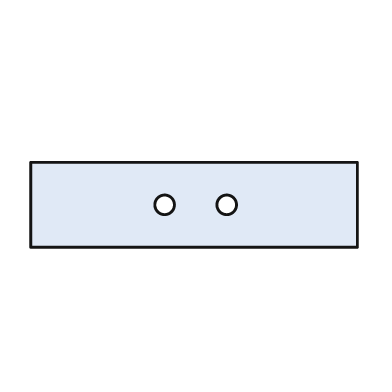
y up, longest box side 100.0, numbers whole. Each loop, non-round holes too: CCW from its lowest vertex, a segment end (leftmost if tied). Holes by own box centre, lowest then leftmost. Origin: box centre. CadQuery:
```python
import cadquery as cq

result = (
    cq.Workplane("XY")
    .moveTo(-50.0, -13.0)
    .lineTo(50.0, -13.0)
    .lineTo(50.0, 13.0)
    .lineTo(-50.0, 13.0)
    .close()
    .moveTo(-9.0, 0.0)
    .circle(3.0)
    .moveTo(10.0, 0.0)
    .circle(3.0)
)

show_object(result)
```